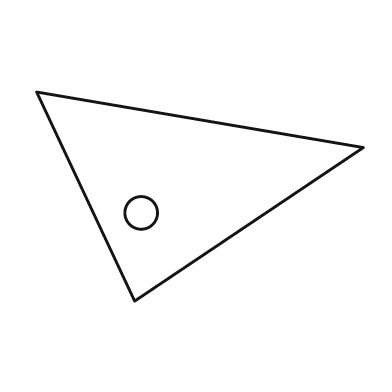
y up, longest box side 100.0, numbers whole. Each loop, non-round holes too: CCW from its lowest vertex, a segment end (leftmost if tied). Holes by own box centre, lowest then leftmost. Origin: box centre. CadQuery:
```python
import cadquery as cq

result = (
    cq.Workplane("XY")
    .moveTo(-20.0, -32.0)
    .lineTo(50.0, 15.0)
    .lineTo(-50.0, 32.0)
    .close()
    .moveTo(-18.0, -5.0)
    .circle(5.0)
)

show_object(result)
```